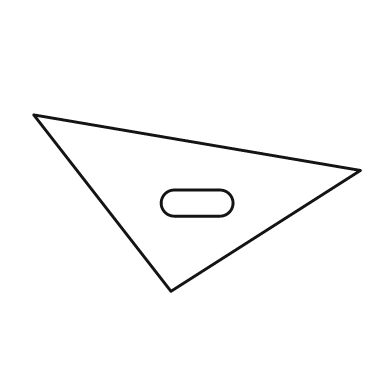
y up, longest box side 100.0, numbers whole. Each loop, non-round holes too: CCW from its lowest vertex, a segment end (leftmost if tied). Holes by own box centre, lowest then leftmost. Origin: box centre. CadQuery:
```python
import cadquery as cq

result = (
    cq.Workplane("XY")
    .moveTo(-8.0, -27.0)
    .lineTo(50.0, 10.0)
    .lineTo(-50.0, 27.0)
    .close()
    .moveTo(-7.0, -4.0)
    .lineTo(7.0, -4.0)
    .threePointArc((11.0, 0.0), (7.0, 4.0))
    .lineTo(-7.0, 4.0)
    .threePointArc((-11.0, 0.0), (-7.0, -4.0))
    .close()
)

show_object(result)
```